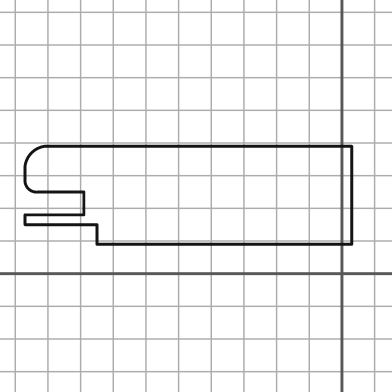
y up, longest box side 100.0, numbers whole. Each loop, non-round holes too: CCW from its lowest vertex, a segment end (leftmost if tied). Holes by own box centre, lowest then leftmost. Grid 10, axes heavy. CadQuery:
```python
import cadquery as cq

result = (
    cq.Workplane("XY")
    .moveTo(-75.0, 9.0)
    .lineTo(3.0, 9.0)
    .lineTo(3.0, 39.0)
    .lineTo(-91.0, 39.0)
    .threePointArc((-95.0, 37.0), (-97.0, 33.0))
    .lineTo(-97.0, 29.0)
    .threePointArc((-96.0, 26.0), (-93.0, 25.0))
    .lineTo(-79.0, 25.0)
    .lineTo(-79.0, 18.0)
    .lineTo(-97.0, 18.0)
    .lineTo(-97.0, 15.0)
    .lineTo(-75.0, 15.0)
    .close()
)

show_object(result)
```